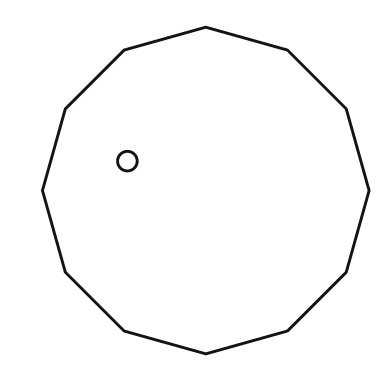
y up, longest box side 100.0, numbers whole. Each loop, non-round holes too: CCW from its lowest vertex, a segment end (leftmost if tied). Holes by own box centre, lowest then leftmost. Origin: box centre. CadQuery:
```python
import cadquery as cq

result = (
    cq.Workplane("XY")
    .moveTo(0.0, -50.0)
    .lineTo(25.0, -43.0)
    .lineTo(43.0, -25.0)
    .lineTo(50.0, 0.0)
    .lineTo(43.0, 25.0)
    .lineTo(25.0, 43.0)
    .lineTo(0.0, 50.0)
    .lineTo(-25.0, 43.0)
    .lineTo(-43.0, 25.0)
    .lineTo(-50.0, 0.0)
    .lineTo(-43.0, -25.0)
    .lineTo(-25.0, -43.0)
    .close()
    .moveTo(-24.0, 9.0)
    .circle(3.0)
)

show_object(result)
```